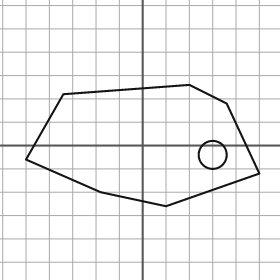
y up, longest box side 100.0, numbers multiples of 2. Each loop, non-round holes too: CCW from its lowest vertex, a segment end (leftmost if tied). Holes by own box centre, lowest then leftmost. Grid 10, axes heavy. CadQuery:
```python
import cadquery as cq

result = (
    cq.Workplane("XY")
    .moveTo(10.0, -26.0)
    .lineTo(50.0, -12.0)
    .lineTo(36.0, 18.0)
    .lineTo(20.0, 26.0)
    .lineTo(-34.0, 22.0)
    .lineTo(-50.0, -6.0)
    .lineTo(-18.0, -20.0)
    .close()
    .moveTo(30.0, -4.0)
    .circle(6.0)
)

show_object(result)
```